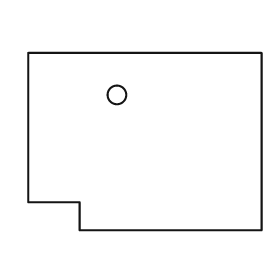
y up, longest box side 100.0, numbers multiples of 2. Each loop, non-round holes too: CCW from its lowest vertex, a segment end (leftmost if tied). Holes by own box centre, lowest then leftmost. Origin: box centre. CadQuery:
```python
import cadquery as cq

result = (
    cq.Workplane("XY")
    .moveTo(-28.0, -38.0)
    .lineTo(50.0, -38.0)
    .lineTo(50.0, 38.0)
    .lineTo(-50.0, 38.0)
    .lineTo(-50.0, -26.0)
    .lineTo(-28.0, -26.0)
    .close()
    .moveTo(-12.0, 20.0)
    .circle(4.0)
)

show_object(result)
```